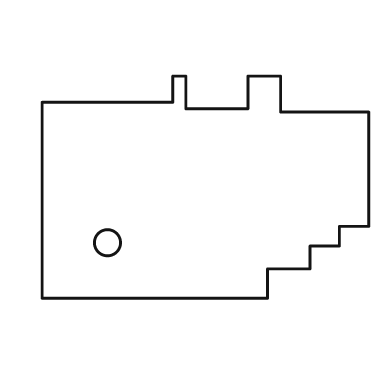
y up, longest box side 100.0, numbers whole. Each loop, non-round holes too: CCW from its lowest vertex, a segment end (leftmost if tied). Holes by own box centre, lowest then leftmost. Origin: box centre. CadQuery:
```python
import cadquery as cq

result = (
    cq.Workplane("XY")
    .moveTo(-50.0, -34.0)
    .lineTo(19.0, -34.0)
    .lineTo(19.0, -25.0)
    .lineTo(32.0, -25.0)
    .lineTo(32.0, -18.0)
    .lineTo(41.0, -18.0)
    .lineTo(41.0, -12.0)
    .lineTo(50.0, -12.0)
    .lineTo(50.0, 23.0)
    .lineTo(23.0, 23.0)
    .lineTo(23.0, 34.0)
    .lineTo(13.0, 34.0)
    .lineTo(13.0, 24.0)
    .lineTo(-6.0, 24.0)
    .lineTo(-6.0, 34.0)
    .lineTo(-10.0, 34.0)
    .lineTo(-10.0, 26.0)
    .lineTo(-50.0, 26.0)
    .close()
    .moveTo(-30.0, -17.0)
    .circle(4.0)
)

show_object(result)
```